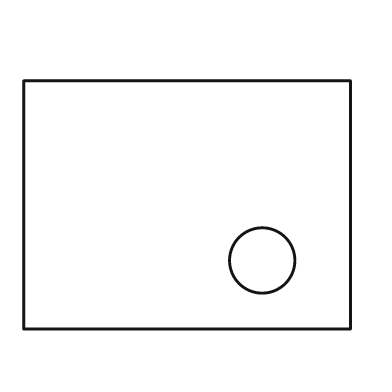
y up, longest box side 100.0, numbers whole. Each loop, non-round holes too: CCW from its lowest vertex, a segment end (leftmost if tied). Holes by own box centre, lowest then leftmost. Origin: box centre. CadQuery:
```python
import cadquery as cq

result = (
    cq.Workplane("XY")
    .moveTo(-50.0, -38.0)
    .lineTo(50.0, -38.0)
    .lineTo(50.0, 38.0)
    .lineTo(-50.0, 38.0)
    .close()
    .moveTo(23.0, -17.0)
    .circle(10.0)
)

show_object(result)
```